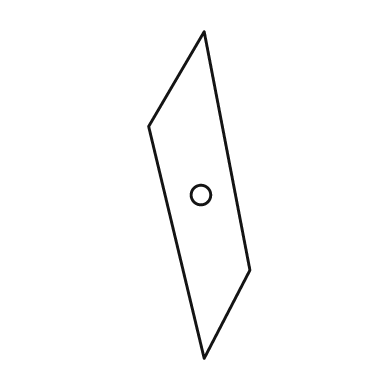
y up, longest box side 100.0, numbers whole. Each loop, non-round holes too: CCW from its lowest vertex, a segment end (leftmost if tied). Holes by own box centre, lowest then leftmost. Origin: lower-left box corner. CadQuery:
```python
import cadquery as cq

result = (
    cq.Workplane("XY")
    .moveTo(17.0, 0.0)
    .lineTo(31.0, 27.0)
    .lineTo(17.0, 100.0)
    .lineTo(0.0, 71.0)
    .close()
    .moveTo(16.0, 50.0)
    .circle(3.0)
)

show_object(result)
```